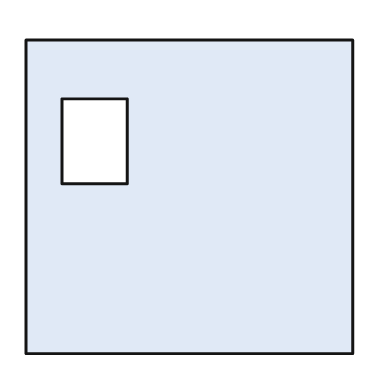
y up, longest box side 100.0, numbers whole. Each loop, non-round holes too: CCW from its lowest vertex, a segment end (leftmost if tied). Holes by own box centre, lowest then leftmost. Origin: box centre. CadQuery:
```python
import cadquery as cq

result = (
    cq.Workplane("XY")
    .moveTo(-50.0, -48.0)
    .lineTo(50.0, -48.0)
    .lineTo(50.0, 48.0)
    .lineTo(-50.0, 48.0)
    .close()
    .moveTo(-39.0, 4.0)
    .lineTo(-19.0, 4.0)
    .lineTo(-19.0, 30.0)
    .lineTo(-39.0, 30.0)
    .close()
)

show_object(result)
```